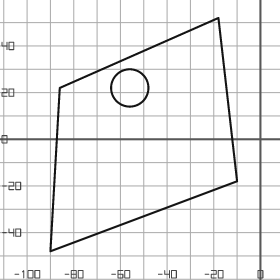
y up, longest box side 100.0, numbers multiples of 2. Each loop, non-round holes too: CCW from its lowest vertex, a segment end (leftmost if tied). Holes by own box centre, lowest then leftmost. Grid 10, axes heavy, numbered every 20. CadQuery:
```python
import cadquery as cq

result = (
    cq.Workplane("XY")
    .moveTo(-90.0, -48.0)
    .lineTo(-10.0, -18.0)
    .lineTo(-18.0, 52.0)
    .lineTo(-86.0, 22.0)
    .close()
    .moveTo(-56.0, 22.0)
    .circle(8.0)
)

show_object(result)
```